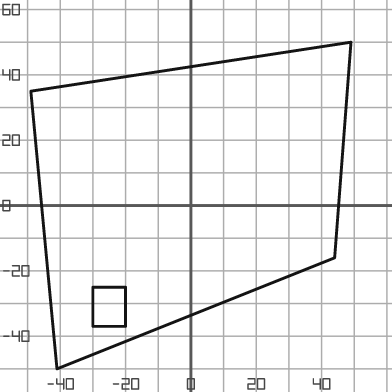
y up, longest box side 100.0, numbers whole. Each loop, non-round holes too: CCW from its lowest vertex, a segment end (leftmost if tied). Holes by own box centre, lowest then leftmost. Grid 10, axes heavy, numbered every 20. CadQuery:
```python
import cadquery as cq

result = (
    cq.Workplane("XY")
    .moveTo(-41.0, -50.0)
    .lineTo(44.0, -16.0)
    .lineTo(49.0, 50.0)
    .lineTo(-49.0, 35.0)
    .close()
    .moveTo(-30.0, -37.0)
    .lineTo(-20.0, -37.0)
    .lineTo(-20.0, -25.0)
    .lineTo(-30.0, -25.0)
    .close()
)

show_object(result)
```